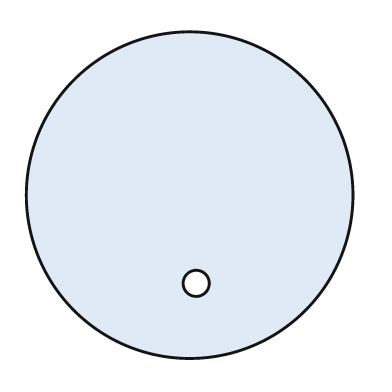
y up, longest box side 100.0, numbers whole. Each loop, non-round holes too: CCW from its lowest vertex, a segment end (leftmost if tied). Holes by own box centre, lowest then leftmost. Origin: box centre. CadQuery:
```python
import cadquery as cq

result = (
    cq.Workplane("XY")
    .moveTo(0.0, 0.0)
    .circle(50.0)
    .moveTo(2.0, -27.0)
    .circle(4.0)
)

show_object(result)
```